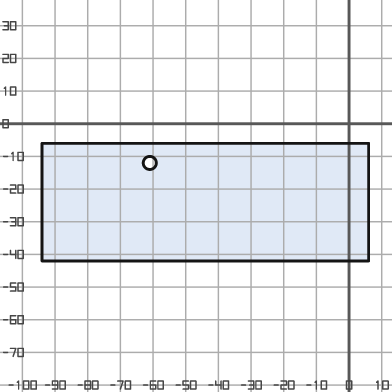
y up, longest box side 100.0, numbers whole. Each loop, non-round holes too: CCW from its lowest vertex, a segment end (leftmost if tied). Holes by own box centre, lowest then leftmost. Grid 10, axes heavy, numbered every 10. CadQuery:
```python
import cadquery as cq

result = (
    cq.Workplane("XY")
    .moveTo(-94.0, -42.0)
    .lineTo(6.0, -42.0)
    .lineTo(6.0, -6.0)
    .lineTo(-94.0, -6.0)
    .close()
    .moveTo(-61.0, -12.0)
    .circle(2.0)
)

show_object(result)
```